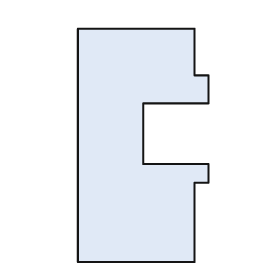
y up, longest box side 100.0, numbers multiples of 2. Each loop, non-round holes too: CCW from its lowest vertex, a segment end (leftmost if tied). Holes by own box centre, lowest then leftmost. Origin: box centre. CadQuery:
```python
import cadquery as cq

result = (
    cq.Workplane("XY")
    .moveTo(-28.0, -50.0)
    .lineTo(22.0, -50.0)
    .lineTo(22.0, -16.0)
    .lineTo(28.0, -16.0)
    .lineTo(28.0, -8.0)
    .lineTo(0.0, -8.0)
    .lineTo(0.0, 18.0)
    .lineTo(28.0, 18.0)
    .lineTo(28.0, 30.0)
    .lineTo(22.0, 30.0)
    .lineTo(22.0, 50.0)
    .lineTo(-28.0, 50.0)
    .close()
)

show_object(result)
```